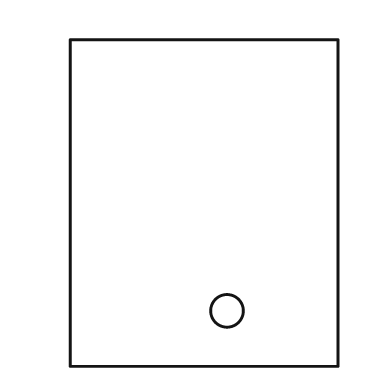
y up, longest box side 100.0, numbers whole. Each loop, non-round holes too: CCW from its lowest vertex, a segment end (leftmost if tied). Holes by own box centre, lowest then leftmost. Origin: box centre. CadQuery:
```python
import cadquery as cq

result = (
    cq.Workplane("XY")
    .moveTo(-41.0, -50.0)
    .lineTo(41.0, -50.0)
    .lineTo(41.0, 50.0)
    .lineTo(-41.0, 50.0)
    .close()
    .moveTo(7.0, -33.0)
    .circle(5.0)
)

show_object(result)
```